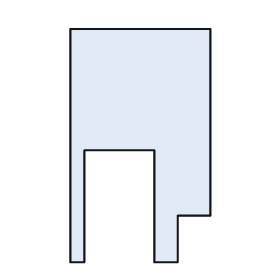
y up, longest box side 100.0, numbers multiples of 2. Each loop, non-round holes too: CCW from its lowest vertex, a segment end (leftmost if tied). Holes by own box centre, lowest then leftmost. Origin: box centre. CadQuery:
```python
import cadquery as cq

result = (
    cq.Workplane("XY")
    .moveTo(-30.0, -50.0)
    .lineTo(-24.0, -50.0)
    .lineTo(-24.0, -2.0)
    .lineTo(6.0, -2.0)
    .lineTo(6.0, -50.0)
    .lineTo(16.0, -50.0)
    .lineTo(16.0, -30.0)
    .lineTo(30.0, -30.0)
    .lineTo(30.0, 50.0)
    .lineTo(-30.0, 50.0)
    .close()
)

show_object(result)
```